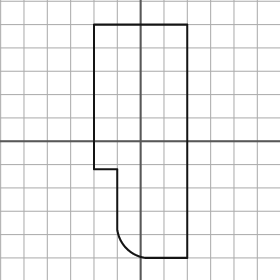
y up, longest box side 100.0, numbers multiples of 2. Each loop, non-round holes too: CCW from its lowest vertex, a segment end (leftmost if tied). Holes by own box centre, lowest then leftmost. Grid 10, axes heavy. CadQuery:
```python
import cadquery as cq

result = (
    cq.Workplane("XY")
    .moveTo(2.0, -50.0)
    .lineTo(20.0, -50.0)
    .lineTo(20.0, 50.0)
    .lineTo(-20.0, 50.0)
    .lineTo(-20.0, -12.0)
    .lineTo(-10.0, -12.0)
    .lineTo(-10.0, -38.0)
    .threePointArc((-6.0, -46.0), (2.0, -50.0))
    .close()
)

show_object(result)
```